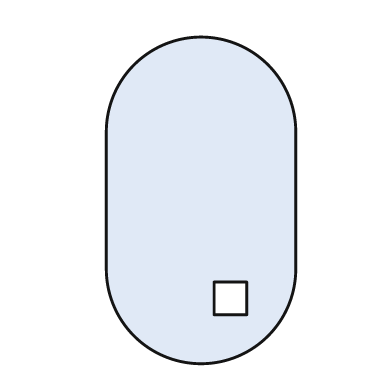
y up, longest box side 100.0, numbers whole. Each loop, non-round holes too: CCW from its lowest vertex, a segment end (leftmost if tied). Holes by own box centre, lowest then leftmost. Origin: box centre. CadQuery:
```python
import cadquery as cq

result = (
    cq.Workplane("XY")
    .moveTo(-29.0, -21.0)
    .threePointArc((0.0, -50.0), (29.0, -21.0))
    .lineTo(29.0, 21.0)
    .threePointArc((0.0, 50.0), (-29.0, 21.0))
    .close()
    .moveTo(4.0, -35.0)
    .lineTo(14.0, -35.0)
    .lineTo(14.0, -25.0)
    .lineTo(4.0, -25.0)
    .close()
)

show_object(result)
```